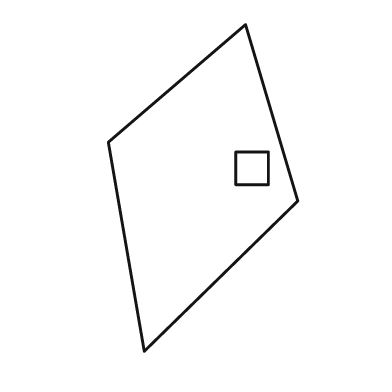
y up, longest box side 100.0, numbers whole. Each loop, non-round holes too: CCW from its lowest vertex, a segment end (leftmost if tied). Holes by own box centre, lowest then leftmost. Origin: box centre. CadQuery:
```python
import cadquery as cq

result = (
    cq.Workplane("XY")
    .moveTo(-18.0, -50.0)
    .lineTo(29.0, -4.0)
    .lineTo(13.0, 50.0)
    .lineTo(-29.0, 14.0)
    .close()
    .moveTo(10.0, 1.0)
    .lineTo(20.0, 1.0)
    .lineTo(20.0, 11.0)
    .lineTo(10.0, 11.0)
    .close()
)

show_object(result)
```